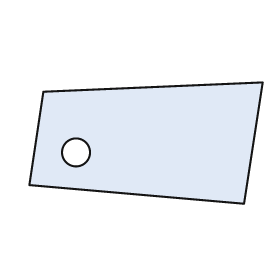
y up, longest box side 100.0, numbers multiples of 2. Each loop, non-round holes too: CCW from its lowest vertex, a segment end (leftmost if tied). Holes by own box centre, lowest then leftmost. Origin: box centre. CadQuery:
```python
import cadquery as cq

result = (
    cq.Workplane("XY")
    .moveTo(42.0, -26.0)
    .lineTo(50.0, 26.0)
    .lineTo(-44.0, 22.0)
    .lineTo(-50.0, -18.0)
    .close()
    .moveTo(-30.0, -4.0)
    .circle(6.0)
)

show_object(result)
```